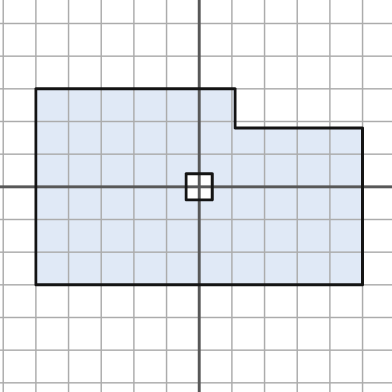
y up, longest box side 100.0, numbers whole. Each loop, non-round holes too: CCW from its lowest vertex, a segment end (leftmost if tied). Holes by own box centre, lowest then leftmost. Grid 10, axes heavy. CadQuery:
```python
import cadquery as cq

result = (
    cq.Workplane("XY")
    .moveTo(-50.0, -30.0)
    .lineTo(50.0, -30.0)
    .lineTo(50.0, 18.0)
    .lineTo(11.0, 18.0)
    .lineTo(11.0, 30.0)
    .lineTo(-50.0, 30.0)
    .close()
    .moveTo(-4.0, -4.0)
    .lineTo(4.0, -4.0)
    .lineTo(4.0, 4.0)
    .lineTo(-4.0, 4.0)
    .close()
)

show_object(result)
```